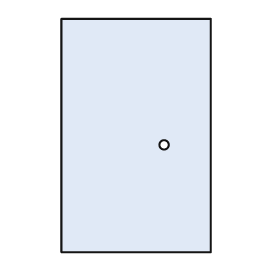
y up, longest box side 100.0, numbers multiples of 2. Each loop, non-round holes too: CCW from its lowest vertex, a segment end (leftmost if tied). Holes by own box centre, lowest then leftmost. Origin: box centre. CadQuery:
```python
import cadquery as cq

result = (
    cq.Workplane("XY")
    .moveTo(-32.0, -50.0)
    .lineTo(32.0, -50.0)
    .lineTo(32.0, 50.0)
    .lineTo(-32.0, 50.0)
    .close()
    .moveTo(12.0, -4.0)
    .circle(2.0)
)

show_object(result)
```